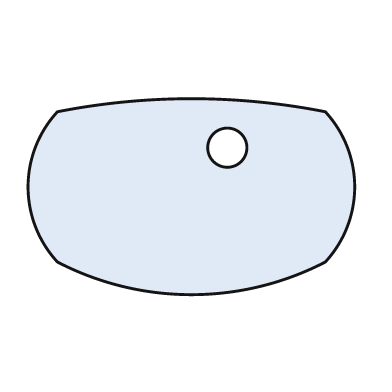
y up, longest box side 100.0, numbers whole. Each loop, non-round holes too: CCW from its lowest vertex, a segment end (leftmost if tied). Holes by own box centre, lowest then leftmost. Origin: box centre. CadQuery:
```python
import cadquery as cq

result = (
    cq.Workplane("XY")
    .moveTo(-41.0, -20.0)
    .threePointArc((0.0, -30.0), (41.0, -20.0))
    .threePointArc((50.0, 3.0), (41.0, 26.0))
    .threePointArc((0.0, 30.0), (-41.0, 26.0))
    .threePointArc((-50.0, 3.0), (-41.0, -20.0))
    .close()
    .moveTo(11.0, 15.0)
    .circle(6.0)
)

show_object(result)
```